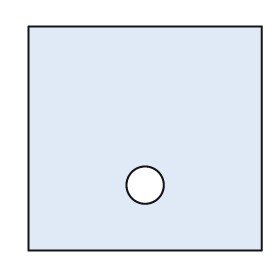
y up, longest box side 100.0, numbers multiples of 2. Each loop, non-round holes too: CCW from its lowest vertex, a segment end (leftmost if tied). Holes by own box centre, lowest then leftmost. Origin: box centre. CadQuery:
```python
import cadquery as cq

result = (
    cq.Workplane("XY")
    .moveTo(-50.0, -48.0)
    .lineTo(50.0, -48.0)
    .lineTo(50.0, 48.0)
    .lineTo(-50.0, 48.0)
    .close()
    .moveTo(0.0, -20.0)
    .circle(8.0)
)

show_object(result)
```